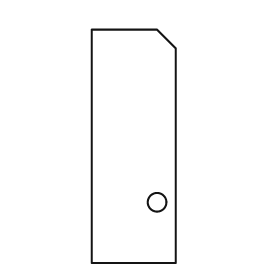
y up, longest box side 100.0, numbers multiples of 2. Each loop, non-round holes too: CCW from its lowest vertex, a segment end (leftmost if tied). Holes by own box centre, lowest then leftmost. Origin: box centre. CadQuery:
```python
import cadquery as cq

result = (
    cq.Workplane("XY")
    .moveTo(-18.0, -50.0)
    .lineTo(18.0, -50.0)
    .lineTo(18.0, 42.0)
    .lineTo(10.0, 50.0)
    .lineTo(-18.0, 50.0)
    .close()
    .moveTo(10.0, -24.0)
    .circle(4.0)
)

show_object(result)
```